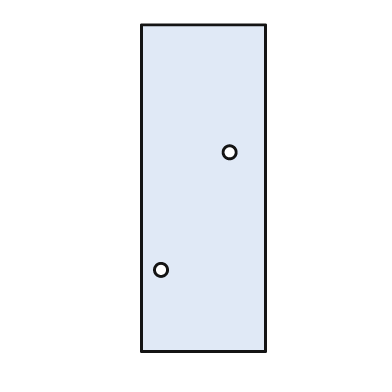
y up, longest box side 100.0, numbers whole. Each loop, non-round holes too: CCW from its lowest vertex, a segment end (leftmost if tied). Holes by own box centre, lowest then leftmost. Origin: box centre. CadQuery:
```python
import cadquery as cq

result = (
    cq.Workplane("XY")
    .moveTo(-19.0, -50.0)
    .lineTo(19.0, -50.0)
    .lineTo(19.0, 50.0)
    .lineTo(-19.0, 50.0)
    .close()
    .moveTo(-13.0, -25.0)
    .circle(2.0)
    .moveTo(8.0, 11.0)
    .circle(2.0)
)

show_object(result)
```